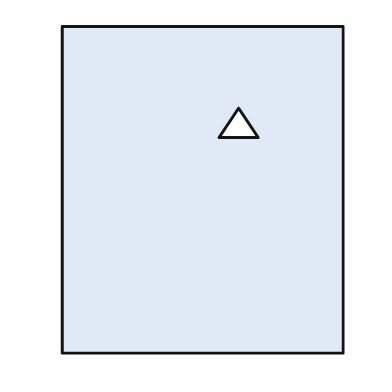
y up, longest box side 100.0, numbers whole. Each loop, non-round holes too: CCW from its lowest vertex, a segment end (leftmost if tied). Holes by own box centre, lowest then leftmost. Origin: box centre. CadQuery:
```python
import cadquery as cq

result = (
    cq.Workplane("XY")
    .moveTo(-43.0, -50.0)
    .lineTo(43.0, -50.0)
    .lineTo(43.0, 50.0)
    .lineTo(-43.0, 50.0)
    .close()
    .moveTo(5.0, 16.0)
    .lineTo(17.0, 16.0)
    .lineTo(11.0, 25.0)
    .close()
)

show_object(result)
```